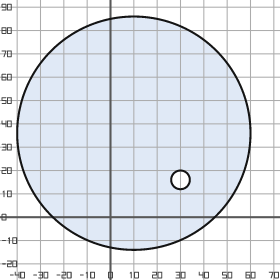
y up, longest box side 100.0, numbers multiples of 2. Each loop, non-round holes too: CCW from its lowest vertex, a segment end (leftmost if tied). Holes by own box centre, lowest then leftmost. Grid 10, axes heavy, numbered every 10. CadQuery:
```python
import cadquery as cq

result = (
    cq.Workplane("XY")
    .moveTo(10.0, 36.0)
    .circle(50.0)
    .moveTo(30.0, 16.0)
    .circle(4.0)
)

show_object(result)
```